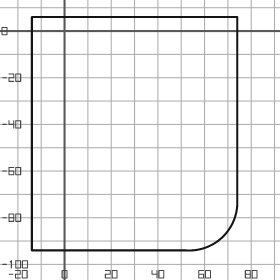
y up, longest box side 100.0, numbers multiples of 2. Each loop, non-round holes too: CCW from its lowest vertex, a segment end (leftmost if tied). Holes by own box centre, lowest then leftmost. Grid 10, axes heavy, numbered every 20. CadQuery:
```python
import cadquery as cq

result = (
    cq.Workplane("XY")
    .moveTo(-14.0, -94.0)
    .lineTo(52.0, -94.0)
    .threePointArc((68.0, -88.0), (74.0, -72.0))
    .lineTo(74.0, 6.0)
    .lineTo(-14.0, 6.0)
    .close()
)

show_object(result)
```